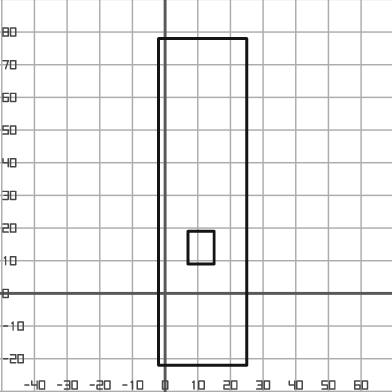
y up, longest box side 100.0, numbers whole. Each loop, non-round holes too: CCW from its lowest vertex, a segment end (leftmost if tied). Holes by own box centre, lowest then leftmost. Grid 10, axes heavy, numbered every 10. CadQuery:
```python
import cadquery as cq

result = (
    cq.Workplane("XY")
    .moveTo(-2.0, -22.0)
    .lineTo(25.0, -22.0)
    .lineTo(25.0, 78.0)
    .lineTo(-2.0, 78.0)
    .close()
    .moveTo(7.0, 9.0)
    .lineTo(15.0, 9.0)
    .lineTo(15.0, 19.0)
    .lineTo(7.0, 19.0)
    .close()
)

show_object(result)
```